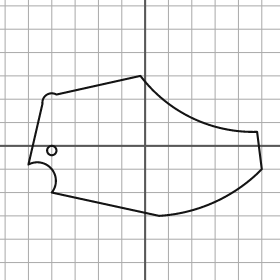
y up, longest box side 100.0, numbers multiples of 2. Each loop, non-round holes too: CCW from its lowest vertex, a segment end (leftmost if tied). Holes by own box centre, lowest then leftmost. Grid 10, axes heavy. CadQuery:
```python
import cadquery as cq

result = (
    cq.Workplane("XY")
    .moveTo(6.0, -30.0)
    .threePointArc((30.0, -24.0), (50.0, -10.0))
    .lineTo(48.0, 6.0)
    .threePointArc((20.0, 12.0), (-2.0, 30.0))
    .lineTo(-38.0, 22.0)
    .threePointArc((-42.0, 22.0), (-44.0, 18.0))
    .lineTo(-50.0, -8.0)
    .threePointArc((-40.0, -10.0), (-40.0, -20.0))
    .close()
    .moveTo(-40.0, -2.0)
    .circle(2.0)
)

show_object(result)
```